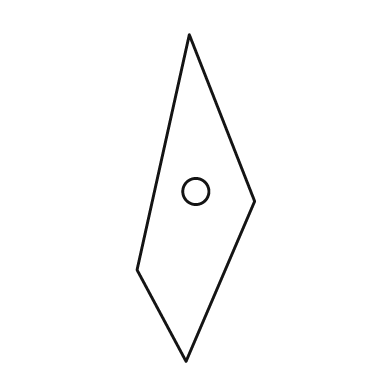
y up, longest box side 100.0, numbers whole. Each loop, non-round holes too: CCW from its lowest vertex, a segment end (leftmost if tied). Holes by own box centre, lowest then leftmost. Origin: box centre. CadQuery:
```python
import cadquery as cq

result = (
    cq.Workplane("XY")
    .moveTo(-3.0, -50.0)
    .lineTo(18.0, -1.0)
    .lineTo(-2.0, 50.0)
    .lineTo(-18.0, -22.0)
    .close()
    .moveTo(0.0, 2.0)
    .circle(4.0)
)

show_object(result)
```